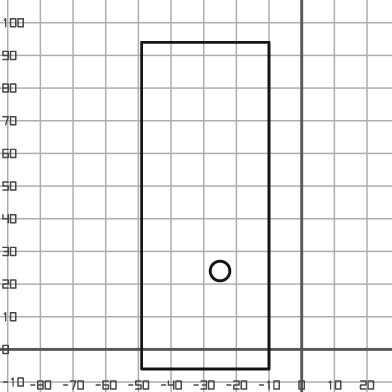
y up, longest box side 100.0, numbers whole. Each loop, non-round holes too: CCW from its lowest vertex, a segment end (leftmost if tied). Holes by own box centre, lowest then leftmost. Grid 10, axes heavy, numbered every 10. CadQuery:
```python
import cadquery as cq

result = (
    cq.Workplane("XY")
    .moveTo(-49.0, -6.0)
    .lineTo(-10.0, -6.0)
    .lineTo(-10.0, 94.0)
    .lineTo(-49.0, 94.0)
    .close()
    .moveTo(-25.0, 24.0)
    .circle(3.0)
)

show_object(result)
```